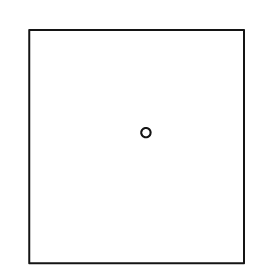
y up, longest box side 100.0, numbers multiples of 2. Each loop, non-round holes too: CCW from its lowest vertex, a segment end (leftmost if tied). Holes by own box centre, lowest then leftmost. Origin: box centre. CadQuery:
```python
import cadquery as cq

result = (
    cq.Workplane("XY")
    .moveTo(-46.0, -50.0)
    .lineTo(46.0, -50.0)
    .lineTo(46.0, 50.0)
    .lineTo(-46.0, 50.0)
    .close()
    .moveTo(4.0, 6.0)
    .circle(2.0)
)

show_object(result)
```